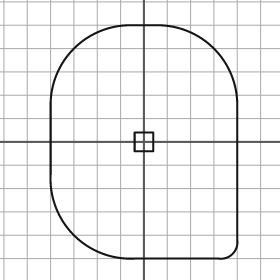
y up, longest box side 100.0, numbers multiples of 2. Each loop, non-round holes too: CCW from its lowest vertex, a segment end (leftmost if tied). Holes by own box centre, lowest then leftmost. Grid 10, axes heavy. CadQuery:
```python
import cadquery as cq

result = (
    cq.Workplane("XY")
    .moveTo(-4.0, -50.0)
    .lineTo(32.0, -50.0)
    .threePointArc((38.0, -48.0), (40.0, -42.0))
    .lineTo(40.0, 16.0)
    .threePointArc((30.0, 40.0), (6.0, 50.0))
    .lineTo(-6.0, 50.0)
    .threePointArc((-30.0, 40.0), (-40.0, 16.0))
    .lineTo(-40.0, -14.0)
    .threePointArc((-30.0, -40.0), (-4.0, -50.0))
    .close()
    .moveTo(-4.0, -4.0)
    .lineTo(4.0, -4.0)
    .lineTo(4.0, 4.0)
    .lineTo(-4.0, 4.0)
    .close()
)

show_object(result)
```